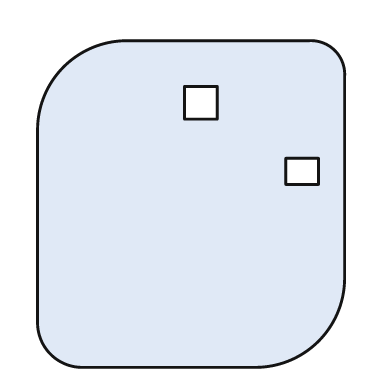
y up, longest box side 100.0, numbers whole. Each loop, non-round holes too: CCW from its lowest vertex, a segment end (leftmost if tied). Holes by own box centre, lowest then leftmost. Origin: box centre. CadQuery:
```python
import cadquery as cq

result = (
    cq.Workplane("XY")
    .moveTo(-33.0, -50.0)
    .lineTo(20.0, -50.0)
    .threePointArc((39.0, -42.0), (47.0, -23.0))
    .lineTo(47.0, 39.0)
    .threePointArc((44.0, 47.0), (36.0, 50.0))
    .lineTo(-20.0, 50.0)
    .threePointArc((-39.0, 42.0), (-47.0, 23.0))
    .lineTo(-47.0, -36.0)
    .threePointArc((-43.0, -46.0), (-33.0, -50.0))
    .close()
    .moveTo(29.0, 6.0)
    .lineTo(39.0, 6.0)
    .lineTo(39.0, 14.0)
    .lineTo(29.0, 14.0)
    .close()
    .moveTo(-2.0, 26.0)
    .lineTo(8.0, 26.0)
    .lineTo(8.0, 36.0)
    .lineTo(-2.0, 36.0)
    .close()
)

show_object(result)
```